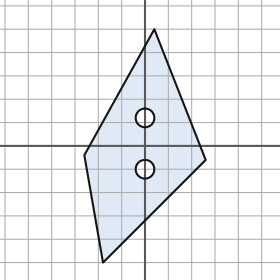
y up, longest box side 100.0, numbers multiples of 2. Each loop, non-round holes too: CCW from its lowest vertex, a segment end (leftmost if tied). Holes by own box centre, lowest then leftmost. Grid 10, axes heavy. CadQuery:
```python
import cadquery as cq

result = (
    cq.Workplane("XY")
    .moveTo(-18.0, -50.0)
    .lineTo(26.0, -6.0)
    .lineTo(4.0, 50.0)
    .lineTo(-26.0, -4.0)
    .close()
    .moveTo(0.0, -10.0)
    .circle(4.0)
    .moveTo(0.0, 12.0)
    .circle(4.0)
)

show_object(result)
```